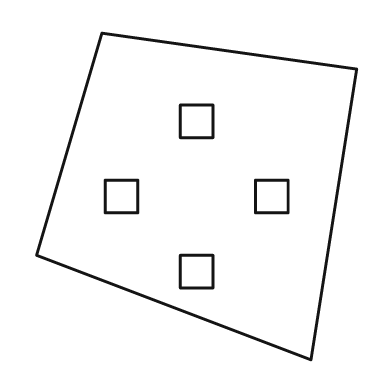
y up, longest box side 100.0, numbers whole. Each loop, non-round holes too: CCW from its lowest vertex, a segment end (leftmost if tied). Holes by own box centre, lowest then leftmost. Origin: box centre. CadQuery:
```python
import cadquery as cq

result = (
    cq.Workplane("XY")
    .moveTo(35.0, -50.0)
    .lineTo(49.0, 39.0)
    .lineTo(-29.0, 50.0)
    .lineTo(-49.0, -18.0)
    .close()
    .moveTo(-5.0, -28.0)
    .lineTo(5.0, -28.0)
    .lineTo(5.0, -18.0)
    .lineTo(-5.0, -18.0)
    .close()
    .moveTo(-28.0, -5.0)
    .lineTo(-18.0, -5.0)
    .lineTo(-18.0, 5.0)
    .lineTo(-28.0, 5.0)
    .close()
    .moveTo(18.0, -5.0)
    .lineTo(28.0, -5.0)
    .lineTo(28.0, 5.0)
    .lineTo(18.0, 5.0)
    .close()
    .moveTo(-5.0, 18.0)
    .lineTo(5.0, 18.0)
    .lineTo(5.0, 28.0)
    .lineTo(-5.0, 28.0)
    .close()
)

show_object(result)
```